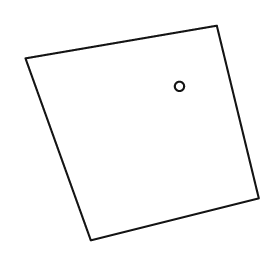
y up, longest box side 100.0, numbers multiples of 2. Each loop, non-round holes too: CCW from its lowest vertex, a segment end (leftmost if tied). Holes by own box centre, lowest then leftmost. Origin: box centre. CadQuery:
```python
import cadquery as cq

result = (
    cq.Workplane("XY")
    .moveTo(-22.0, -46.0)
    .lineTo(50.0, -28.0)
    .lineTo(32.0, 46.0)
    .lineTo(-50.0, 32.0)
    .close()
    .moveTo(16.0, 20.0)
    .circle(2.0)
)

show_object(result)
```